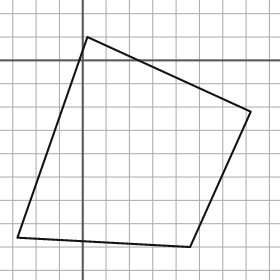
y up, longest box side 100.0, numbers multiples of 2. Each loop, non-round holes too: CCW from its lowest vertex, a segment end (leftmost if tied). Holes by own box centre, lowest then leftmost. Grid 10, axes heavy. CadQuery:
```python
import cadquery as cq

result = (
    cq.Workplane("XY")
    .moveTo(46.0, -80.0)
    .lineTo(72.0, -22.0)
    .lineTo(2.0, 10.0)
    .lineTo(-28.0, -76.0)
    .close()
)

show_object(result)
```